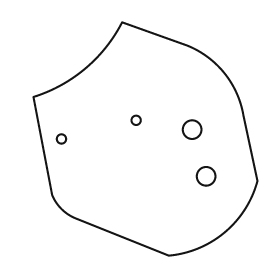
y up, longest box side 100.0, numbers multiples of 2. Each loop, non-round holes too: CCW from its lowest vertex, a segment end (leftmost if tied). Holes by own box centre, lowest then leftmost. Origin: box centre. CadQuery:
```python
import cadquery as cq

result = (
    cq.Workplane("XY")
    .moveTo(10.0, -50.0)
    .threePointArc((34.0, -40.0), (48.0, -18.0))
    .lineTo(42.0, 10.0)
    .threePointArc((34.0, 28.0), (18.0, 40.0))
    .lineTo(-10.0, 50.0)
    .threePointArc((-26.0, 30.0), (-48.0, 18.0))
    .lineTo(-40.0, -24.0)
    .threePointArc((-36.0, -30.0), (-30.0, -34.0))
    .close()
    .moveTo(26.0, -16.0)
    .circle(4.0)
    .moveTo(-36.0, 0.0)
    .circle(2.0)
    .moveTo(20.0, 4.0)
    .circle(4.0)
    .moveTo(-4.0, 8.0)
    .circle(2.0)
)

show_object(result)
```